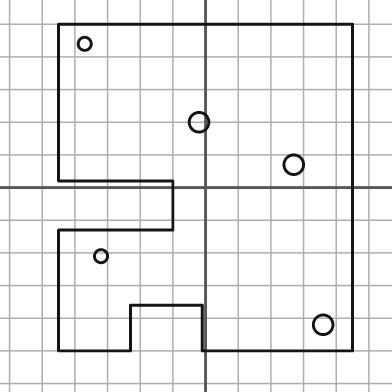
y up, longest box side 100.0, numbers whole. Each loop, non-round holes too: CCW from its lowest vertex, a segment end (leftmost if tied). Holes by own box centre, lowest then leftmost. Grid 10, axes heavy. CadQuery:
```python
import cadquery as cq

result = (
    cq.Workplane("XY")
    .moveTo(-45.0, -50.0)
    .lineTo(-23.0, -50.0)
    .lineTo(-23.0, -36.0)
    .lineTo(-1.0, -36.0)
    .lineTo(-1.0, -50.0)
    .lineTo(45.0, -50.0)
    .lineTo(45.0, 50.0)
    .lineTo(-45.0, 50.0)
    .lineTo(-45.0, 2.0)
    .lineTo(-10.0, 2.0)
    .lineTo(-10.0, -13.0)
    .lineTo(-45.0, -13.0)
    .close()
    .moveTo(36.0, -42.0)
    .circle(3.0)
    .moveTo(-32.0, -21.0)
    .circle(2.0)
    .moveTo(27.0, 7.0)
    .circle(3.0)
    .moveTo(-2.0, 20.0)
    .circle(3.0)
    .moveTo(-37.0, 44.0)
    .circle(2.0)
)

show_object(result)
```